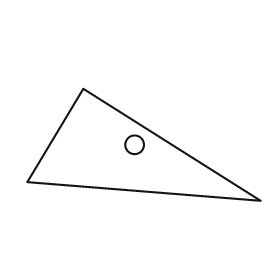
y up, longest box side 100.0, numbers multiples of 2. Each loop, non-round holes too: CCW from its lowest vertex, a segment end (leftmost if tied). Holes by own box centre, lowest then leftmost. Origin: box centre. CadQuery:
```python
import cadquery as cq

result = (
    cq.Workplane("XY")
    .moveTo(50.0, -24.0)
    .lineTo(-26.0, 24.0)
    .lineTo(-50.0, -16.0)
    .close()
    .moveTo(-4.0, 0.0)
    .circle(4.0)
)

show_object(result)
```